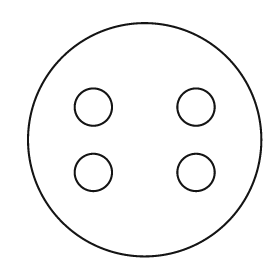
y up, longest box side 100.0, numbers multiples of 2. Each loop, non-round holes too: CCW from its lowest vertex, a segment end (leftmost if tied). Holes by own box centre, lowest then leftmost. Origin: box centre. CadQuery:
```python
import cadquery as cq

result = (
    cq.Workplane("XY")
    .moveTo(0.0, 0.0)
    .circle(50.0)
    .moveTo(-22.0, -14.0)
    .circle(8.0)
    .moveTo(22.0, -14.0)
    .circle(8.0)
    .moveTo(-22.0, 14.0)
    .circle(8.0)
    .moveTo(22.0, 14.0)
    .circle(8.0)
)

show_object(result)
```